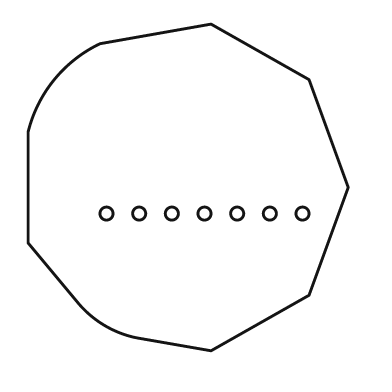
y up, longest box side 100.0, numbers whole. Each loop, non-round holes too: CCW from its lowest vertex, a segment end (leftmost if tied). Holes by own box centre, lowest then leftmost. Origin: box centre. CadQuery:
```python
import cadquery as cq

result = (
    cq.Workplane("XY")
    .moveTo(7.0, -50.0)
    .lineTo(37.0, -33.0)
    .lineTo(49.0, 0.0)
    .lineTo(37.0, 33.0)
    .lineTo(7.0, 50.0)
    .lineTo(-27.0, 44.0)
    .threePointArc((-41.0, 33.0), (-49.0, 17.0))
    .lineTo(-49.0, -17.0)
    .lineTo(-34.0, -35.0)
    .threePointArc((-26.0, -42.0), (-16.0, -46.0))
    .close()
    .moveTo(-25.0, -8.0)
    .circle(2.0)
    .moveTo(-15.0, -8.0)
    .circle(2.0)
    .moveTo(-5.0, -8.0)
    .circle(2.0)
    .moveTo(5.0, -8.0)
    .circle(2.0)
    .moveTo(15.0, -8.0)
    .circle(2.0)
    .moveTo(25.0, -8.0)
    .circle(2.0)
    .moveTo(35.0, -8.0)
    .circle(2.0)
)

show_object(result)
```